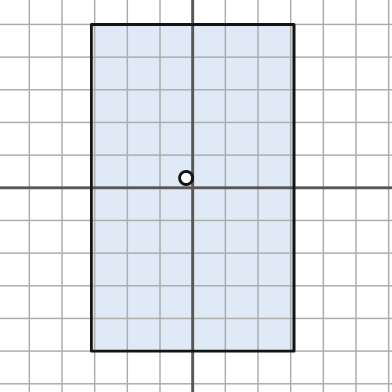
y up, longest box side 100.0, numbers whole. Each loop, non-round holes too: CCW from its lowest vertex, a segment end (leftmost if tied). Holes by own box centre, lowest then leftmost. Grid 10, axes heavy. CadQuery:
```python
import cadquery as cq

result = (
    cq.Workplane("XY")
    .moveTo(-31.0, -50.0)
    .lineTo(31.0, -50.0)
    .lineTo(31.0, 50.0)
    .lineTo(-31.0, 50.0)
    .close()
    .moveTo(-2.0, 3.0)
    .circle(2.0)
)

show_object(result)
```